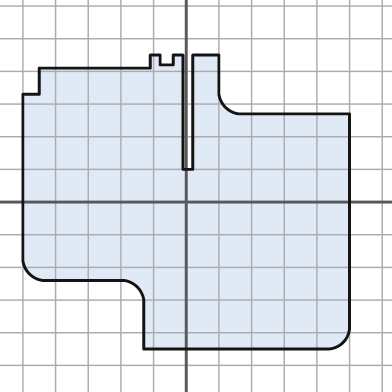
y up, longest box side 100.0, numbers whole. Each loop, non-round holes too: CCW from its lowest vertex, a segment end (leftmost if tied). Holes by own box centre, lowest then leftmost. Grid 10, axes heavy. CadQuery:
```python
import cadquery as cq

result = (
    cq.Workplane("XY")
    .moveTo(-13.0, -45.0)
    .lineTo(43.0, -45.0)
    .threePointArc((48.0, -43.0), (50.0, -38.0))
    .lineTo(50.0, 27.0)
    .lineTo(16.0, 27.0)
    .threePointArc((12.0, 29.0), (10.0, 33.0))
    .lineTo(10.0, 45.0)
    .lineTo(2.0, 45.0)
    .lineTo(2.0, 10.0)
    .lineTo(-1.0, 10.0)
    .lineTo(-1.0, 45.0)
    .lineTo(-4.0, 45.0)
    .lineTo(-4.0, 42.0)
    .lineTo(-8.0, 42.0)
    .lineTo(-8.0, 45.0)
    .lineTo(-11.0, 45.0)
    .lineTo(-11.0, 41.0)
    .lineTo(-45.0, 41.0)
    .lineTo(-45.0, 33.0)
    .lineTo(-50.0, 33.0)
    .lineTo(-50.0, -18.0)
    .threePointArc((-48.0, -22.0), (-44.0, -24.0))
    .lineTo(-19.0, -24.0)
    .threePointArc((-15.0, -26.0), (-13.0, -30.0))
    .close()
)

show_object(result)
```